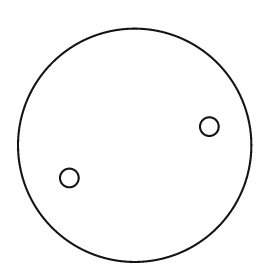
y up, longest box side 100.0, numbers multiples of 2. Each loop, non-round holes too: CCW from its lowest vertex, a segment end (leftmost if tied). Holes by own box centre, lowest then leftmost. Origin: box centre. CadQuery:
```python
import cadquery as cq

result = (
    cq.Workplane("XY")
    .moveTo(0.0, 0.0)
    .circle(50.0)
    .moveTo(-28.0, -14.0)
    .circle(4.0)
    .moveTo(32.0, 8.0)
    .circle(4.0)
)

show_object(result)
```